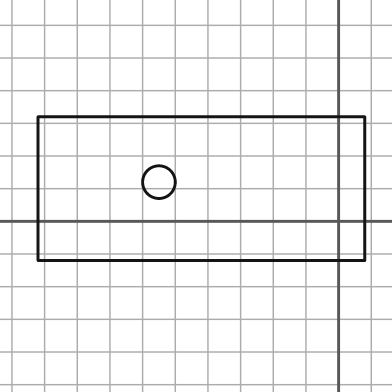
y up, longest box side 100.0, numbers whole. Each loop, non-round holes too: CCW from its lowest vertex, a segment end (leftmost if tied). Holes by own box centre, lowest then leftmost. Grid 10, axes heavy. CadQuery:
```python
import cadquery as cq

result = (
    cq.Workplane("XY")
    .moveTo(-92.0, -12.0)
    .lineTo(8.0, -12.0)
    .lineTo(8.0, 32.0)
    .lineTo(-92.0, 32.0)
    .close()
    .moveTo(-55.0, 12.0)
    .circle(5.0)
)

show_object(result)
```